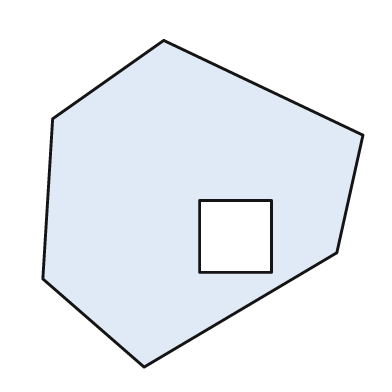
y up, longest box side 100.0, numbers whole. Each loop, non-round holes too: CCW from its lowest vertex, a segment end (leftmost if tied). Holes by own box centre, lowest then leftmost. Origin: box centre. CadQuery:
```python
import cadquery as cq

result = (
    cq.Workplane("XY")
    .moveTo(-18.0, -50.0)
    .lineTo(41.0, -15.0)
    .lineTo(49.0, 21.0)
    .lineTo(-12.0, 50.0)
    .lineTo(-46.0, 26.0)
    .lineTo(-49.0, -23.0)
    .close()
    .moveTo(-1.0, -21.0)
    .lineTo(21.0, -21.0)
    .lineTo(21.0, 1.0)
    .lineTo(-1.0, 1.0)
    .close()
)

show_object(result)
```